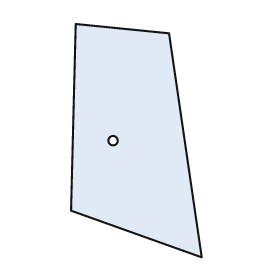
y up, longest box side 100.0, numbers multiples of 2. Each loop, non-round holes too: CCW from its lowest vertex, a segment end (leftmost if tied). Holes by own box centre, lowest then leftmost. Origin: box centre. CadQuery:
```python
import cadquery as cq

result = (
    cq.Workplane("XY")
    .moveTo(28.0, -50.0)
    .lineTo(14.0, 46.0)
    .lineTo(-26.0, 50.0)
    .lineTo(-28.0, -30.0)
    .close()
    .moveTo(-10.0, 0.0)
    .circle(2.0)
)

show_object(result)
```